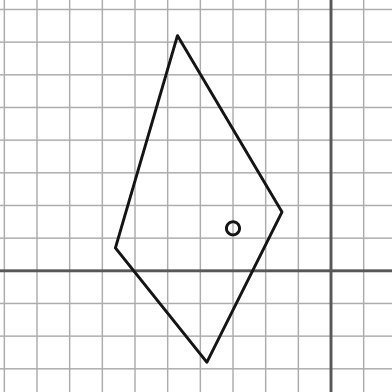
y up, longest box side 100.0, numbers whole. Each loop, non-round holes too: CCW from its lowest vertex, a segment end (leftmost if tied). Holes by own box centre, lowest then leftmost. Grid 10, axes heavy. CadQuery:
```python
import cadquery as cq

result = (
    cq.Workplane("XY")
    .moveTo(-38.0, -28.0)
    .lineTo(-15.0, 18.0)
    .lineTo(-47.0, 72.0)
    .lineTo(-66.0, 7.0)
    .close()
    .moveTo(-30.0, 13.0)
    .circle(2.0)
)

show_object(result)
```